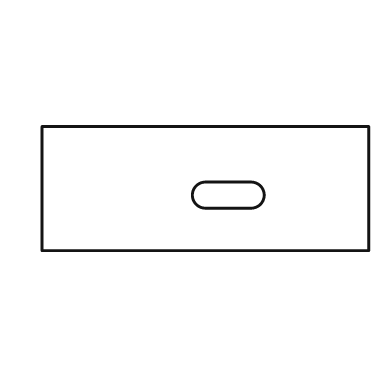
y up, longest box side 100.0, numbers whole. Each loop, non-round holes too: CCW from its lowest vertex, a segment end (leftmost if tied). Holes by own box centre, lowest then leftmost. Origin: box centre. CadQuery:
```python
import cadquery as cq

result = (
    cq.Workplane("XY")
    .moveTo(-50.0, -19.0)
    .lineTo(50.0, -19.0)
    .lineTo(50.0, 19.0)
    .lineTo(-50.0, 19.0)
    .close()
    .moveTo(0.0, -6.0)
    .lineTo(14.0, -6.0)
    .threePointArc((18.0, -2.0), (14.0, 2.0))
    .lineTo(0.0, 2.0)
    .threePointArc((-4.0, -2.0), (0.0, -6.0))
    .close()
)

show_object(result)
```